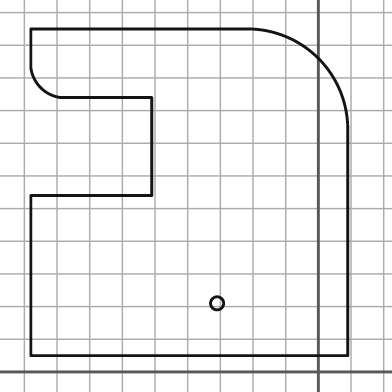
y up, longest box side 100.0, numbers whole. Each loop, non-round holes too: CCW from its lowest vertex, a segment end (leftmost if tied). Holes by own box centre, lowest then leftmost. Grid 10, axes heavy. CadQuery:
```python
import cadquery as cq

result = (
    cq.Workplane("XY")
    .moveTo(-88.0, 5.0)
    .lineTo(9.0, 5.0)
    .lineTo(9.0, 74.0)
    .threePointArc((0.0, 96.0), (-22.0, 105.0))
    .lineTo(-88.0, 105.0)
    .lineTo(-88.0, 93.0)
    .threePointArc((-85.0, 87.0), (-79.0, 84.0))
    .lineTo(-51.0, 84.0)
    .lineTo(-51.0, 54.0)
    .lineTo(-88.0, 54.0)
    .close()
    .moveTo(-31.0, 21.0)
    .circle(2.0)
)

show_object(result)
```